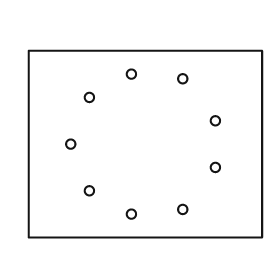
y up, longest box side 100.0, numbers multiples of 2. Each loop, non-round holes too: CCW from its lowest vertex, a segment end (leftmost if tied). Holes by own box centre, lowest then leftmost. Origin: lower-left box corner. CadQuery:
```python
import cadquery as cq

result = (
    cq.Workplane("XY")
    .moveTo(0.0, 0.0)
    .lineTo(100.0, 0.0)
    .lineTo(100.0, 80.0)
    .lineTo(0.0, 80.0)
    .close()
    .moveTo(44.0, 10.0)
    .circle(2.0)
    .moveTo(66.0, 12.0)
    .circle(2.0)
    .moveTo(26.0, 20.0)
    .circle(2.0)
    .moveTo(80.0, 30.0)
    .circle(2.0)
    .moveTo(18.0, 40.0)
    .circle(2.0)
    .moveTo(80.0, 50.0)
    .circle(2.0)
    .moveTo(26.0, 60.0)
    .circle(2.0)
    .moveTo(66.0, 68.0)
    .circle(2.0)
    .moveTo(44.0, 70.0)
    .circle(2.0)
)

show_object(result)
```